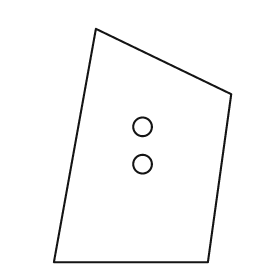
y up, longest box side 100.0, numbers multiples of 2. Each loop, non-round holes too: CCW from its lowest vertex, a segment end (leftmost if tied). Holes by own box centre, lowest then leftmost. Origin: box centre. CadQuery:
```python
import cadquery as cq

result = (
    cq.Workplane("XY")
    .moveTo(-38.0, -50.0)
    .lineTo(28.0, -50.0)
    .lineTo(38.0, 22.0)
    .lineTo(-20.0, 50.0)
    .close()
    .moveTo(0.0, -8.0)
    .circle(4.0)
    .moveTo(0.0, 8.0)
    .circle(4.0)
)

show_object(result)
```